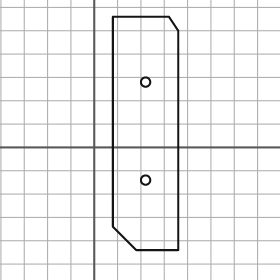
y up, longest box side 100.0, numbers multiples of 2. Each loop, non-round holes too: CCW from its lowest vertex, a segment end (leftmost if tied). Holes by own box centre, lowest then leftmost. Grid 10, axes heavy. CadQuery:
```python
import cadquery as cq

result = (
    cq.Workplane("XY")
    .moveTo(18.0, -44.0)
    .lineTo(36.0, -44.0)
    .lineTo(36.0, 50.0)
    .lineTo(32.0, 56.0)
    .lineTo(8.0, 56.0)
    .lineTo(8.0, -34.0)
    .close()
    .moveTo(22.0, -14.0)
    .circle(2.0)
    .moveTo(22.0, 28.0)
    .circle(2.0)
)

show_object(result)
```